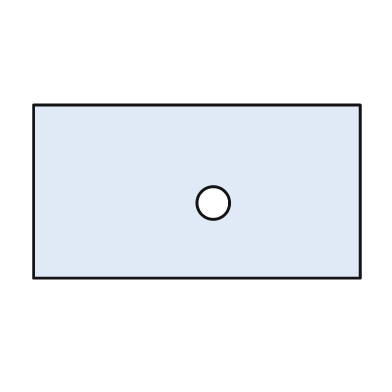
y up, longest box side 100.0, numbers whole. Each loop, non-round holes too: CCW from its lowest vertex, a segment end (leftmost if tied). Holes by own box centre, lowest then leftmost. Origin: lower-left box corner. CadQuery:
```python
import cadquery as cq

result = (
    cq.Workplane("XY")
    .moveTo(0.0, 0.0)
    .lineTo(100.0, 0.0)
    .lineTo(100.0, 53.0)
    .lineTo(0.0, 53.0)
    .close()
    .moveTo(55.0, 23.0)
    .circle(5.0)
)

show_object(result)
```